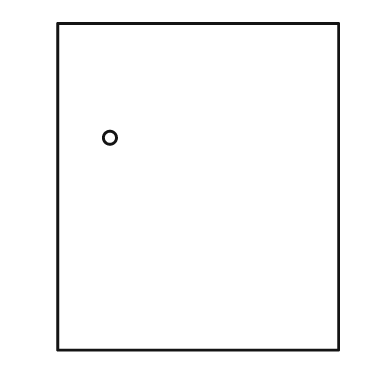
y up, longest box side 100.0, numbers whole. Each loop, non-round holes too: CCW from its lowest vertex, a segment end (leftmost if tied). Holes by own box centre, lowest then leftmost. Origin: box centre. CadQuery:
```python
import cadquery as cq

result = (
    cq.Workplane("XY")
    .moveTo(-43.0, -50.0)
    .lineTo(43.0, -50.0)
    .lineTo(43.0, 50.0)
    .lineTo(-43.0, 50.0)
    .close()
    .moveTo(-27.0, 15.0)
    .circle(2.0)
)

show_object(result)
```